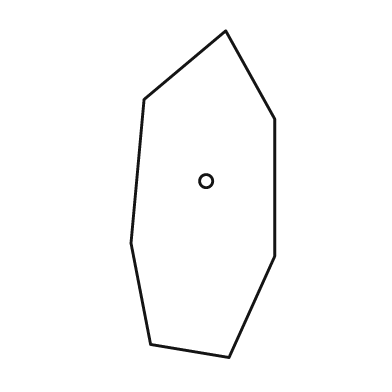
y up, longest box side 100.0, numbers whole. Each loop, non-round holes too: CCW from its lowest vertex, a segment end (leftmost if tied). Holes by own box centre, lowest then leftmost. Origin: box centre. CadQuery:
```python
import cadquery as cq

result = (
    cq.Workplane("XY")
    .moveTo(8.0, -50.0)
    .lineTo(22.0, -19.0)
    .lineTo(22.0, 23.0)
    .lineTo(7.0, 50.0)
    .lineTo(-18.0, 29.0)
    .lineTo(-22.0, -15.0)
    .lineTo(-16.0, -46.0)
    .close()
    .moveTo(1.0, 4.0)
    .circle(2.0)
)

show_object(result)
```